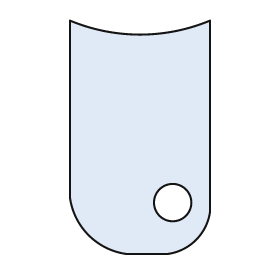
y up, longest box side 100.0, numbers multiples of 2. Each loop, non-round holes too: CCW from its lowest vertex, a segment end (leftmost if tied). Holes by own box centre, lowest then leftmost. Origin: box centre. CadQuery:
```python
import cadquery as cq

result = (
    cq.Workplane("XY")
    .moveTo(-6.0, -50.0)
    .lineTo(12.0, -50.0)
    .threePointArc((24.0, -44.0), (30.0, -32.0))
    .lineTo(30.0, 50.0)
    .threePointArc((0.0, 44.0), (-30.0, 50.0))
    .lineTo(-30.0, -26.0)
    .threePointArc((-22.0, -42.0), (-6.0, -50.0))
    .close()
    .moveTo(14.0, -28.0)
    .circle(8.0)
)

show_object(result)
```